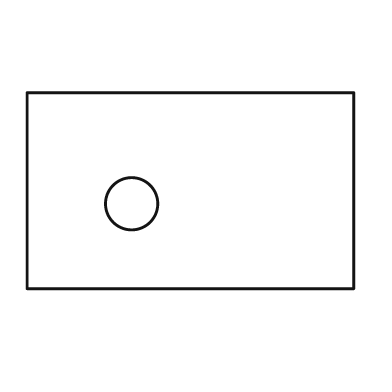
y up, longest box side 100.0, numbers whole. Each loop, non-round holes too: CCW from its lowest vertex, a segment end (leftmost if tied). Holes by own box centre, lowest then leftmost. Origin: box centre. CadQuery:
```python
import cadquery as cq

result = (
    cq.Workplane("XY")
    .moveTo(-50.0, -30.0)
    .lineTo(50.0, -30.0)
    .lineTo(50.0, 30.0)
    .lineTo(-50.0, 30.0)
    .close()
    .moveTo(-18.0, -4.0)
    .circle(8.0)
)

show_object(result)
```